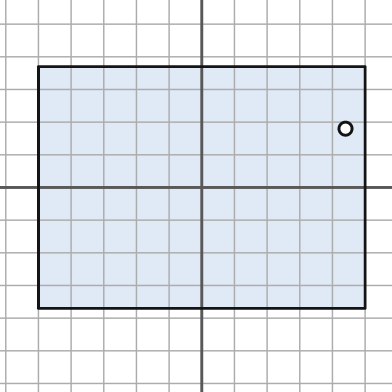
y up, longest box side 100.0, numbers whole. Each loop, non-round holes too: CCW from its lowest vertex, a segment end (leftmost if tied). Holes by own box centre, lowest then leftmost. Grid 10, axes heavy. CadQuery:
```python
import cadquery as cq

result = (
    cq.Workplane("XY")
    .moveTo(-50.0, -37.0)
    .lineTo(50.0, -37.0)
    .lineTo(50.0, 37.0)
    .lineTo(-50.0, 37.0)
    .close()
    .moveTo(44.0, 18.0)
    .circle(2.0)
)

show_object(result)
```